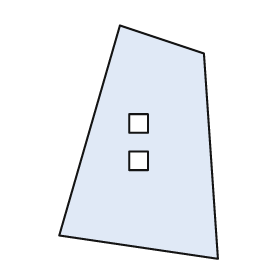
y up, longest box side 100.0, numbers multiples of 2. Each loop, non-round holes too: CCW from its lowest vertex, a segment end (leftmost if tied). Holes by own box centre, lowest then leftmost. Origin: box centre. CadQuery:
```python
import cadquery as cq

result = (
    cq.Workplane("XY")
    .moveTo(34.0, -50.0)
    .lineTo(28.0, 38.0)
    .lineTo(-8.0, 50.0)
    .lineTo(-34.0, -40.0)
    .close()
    .moveTo(-4.0, -12.0)
    .lineTo(4.0, -12.0)
    .lineTo(4.0, -4.0)
    .lineTo(-4.0, -4.0)
    .close()
    .moveTo(-4.0, 4.0)
    .lineTo(4.0, 4.0)
    .lineTo(4.0, 12.0)
    .lineTo(-4.0, 12.0)
    .close()
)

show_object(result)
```